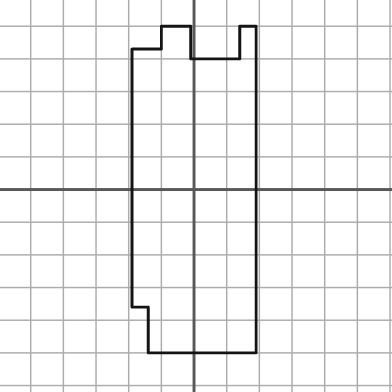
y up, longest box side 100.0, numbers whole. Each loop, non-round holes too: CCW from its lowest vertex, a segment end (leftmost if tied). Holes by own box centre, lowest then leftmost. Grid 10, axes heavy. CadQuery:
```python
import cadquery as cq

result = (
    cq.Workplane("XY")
    .moveTo(-14.0, -50.0)
    .lineTo(19.0, -50.0)
    .lineTo(19.0, 50.0)
    .lineTo(14.0, 50.0)
    .lineTo(14.0, 40.0)
    .lineTo(-1.0, 40.0)
    .lineTo(-1.0, 50.0)
    .lineTo(-10.0, 50.0)
    .lineTo(-10.0, 43.0)
    .lineTo(-19.0, 43.0)
    .lineTo(-19.0, -36.0)
    .lineTo(-14.0, -36.0)
    .close()
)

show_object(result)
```